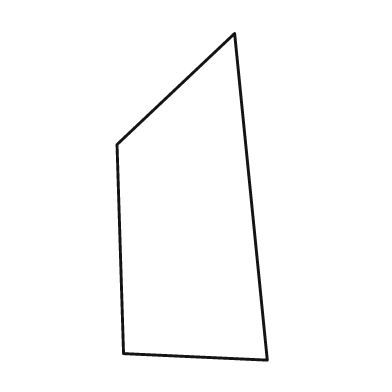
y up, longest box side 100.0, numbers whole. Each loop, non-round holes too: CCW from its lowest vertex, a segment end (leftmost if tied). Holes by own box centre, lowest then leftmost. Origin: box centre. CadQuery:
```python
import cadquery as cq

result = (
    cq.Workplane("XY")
    .moveTo(23.0, -50.0)
    .lineTo(13.0, 50.0)
    .lineTo(-23.0, 16.0)
    .lineTo(-21.0, -48.0)
    .close()
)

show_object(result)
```